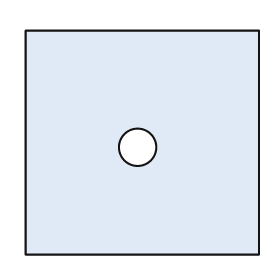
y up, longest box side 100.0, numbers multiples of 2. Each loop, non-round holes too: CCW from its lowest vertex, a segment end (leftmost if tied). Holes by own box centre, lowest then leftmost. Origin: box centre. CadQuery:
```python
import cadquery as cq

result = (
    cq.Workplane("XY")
    .moveTo(-50.0, -48.0)
    .lineTo(50.0, -48.0)
    .lineTo(50.0, 48.0)
    .lineTo(-50.0, 48.0)
    .close()
    .moveTo(-2.0, -2.0)
    .circle(8.0)
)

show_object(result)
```